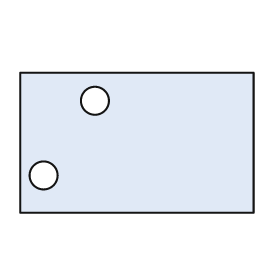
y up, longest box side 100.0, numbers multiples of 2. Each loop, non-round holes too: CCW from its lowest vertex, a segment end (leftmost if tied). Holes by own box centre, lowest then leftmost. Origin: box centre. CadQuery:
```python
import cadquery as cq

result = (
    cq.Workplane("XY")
    .moveTo(-50.0, -30.0)
    .lineTo(50.0, -30.0)
    .lineTo(50.0, 30.0)
    .lineTo(-50.0, 30.0)
    .close()
    .moveTo(-40.0, -14.0)
    .circle(6.0)
    .moveTo(-18.0, 18.0)
    .circle(6.0)
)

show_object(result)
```